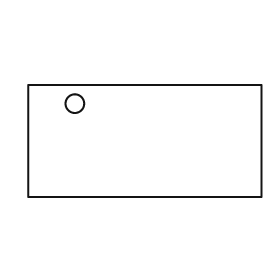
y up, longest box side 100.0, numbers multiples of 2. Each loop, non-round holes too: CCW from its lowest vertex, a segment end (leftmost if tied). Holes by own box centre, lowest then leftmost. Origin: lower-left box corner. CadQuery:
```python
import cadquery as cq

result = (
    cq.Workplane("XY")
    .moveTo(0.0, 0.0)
    .lineTo(100.0, 0.0)
    .lineTo(100.0, 48.0)
    .lineTo(0.0, 48.0)
    .close()
    .moveTo(20.0, 40.0)
    .circle(4.0)
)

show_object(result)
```